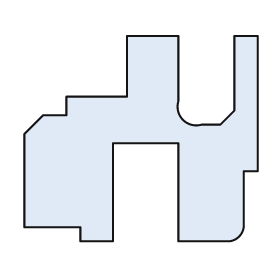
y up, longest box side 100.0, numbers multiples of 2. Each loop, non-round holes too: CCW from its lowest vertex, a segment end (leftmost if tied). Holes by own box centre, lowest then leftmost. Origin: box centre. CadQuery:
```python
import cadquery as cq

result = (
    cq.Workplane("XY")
    .moveTo(-26.0, -44.0)
    .lineTo(-12.0, -44.0)
    .lineTo(-12.0, -2.0)
    .lineTo(16.0, -2.0)
    .lineTo(16.0, -44.0)
    .lineTo(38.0, -44.0)
    .threePointArc((42.0, -42.0), (44.0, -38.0))
    .lineTo(44.0, -14.0)
    .lineTo(50.0, -14.0)
    .lineTo(50.0, 44.0)
    .lineTo(40.0, 44.0)
    .lineTo(40.0, 12.0)
    .lineTo(34.0, 6.0)
    .lineTo(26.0, 6.0)
    .threePointArc((18.0, 8.0), (16.0, 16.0))
    .lineTo(16.0, 44.0)
    .lineTo(-6.0, 44.0)
    .lineTo(-6.0, 18.0)
    .lineTo(-32.0, 18.0)
    .lineTo(-32.0, 10.0)
    .lineTo(-42.0, 10.0)
    .lineTo(-50.0, 2.0)
    .lineTo(-50.0, -38.0)
    .lineTo(-26.0, -38.0)
    .close()
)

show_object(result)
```